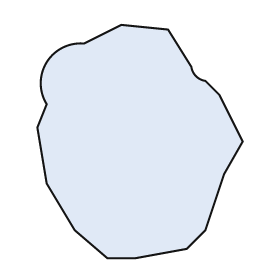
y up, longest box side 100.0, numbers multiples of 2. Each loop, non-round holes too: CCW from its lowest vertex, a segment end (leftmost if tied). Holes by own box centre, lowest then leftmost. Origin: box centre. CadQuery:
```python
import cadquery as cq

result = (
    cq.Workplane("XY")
    .moveTo(-14.0, -50.0)
    .lineTo(-2.0, -50.0)
    .lineTo(20.0, -46.0)
    .lineTo(28.0, -38.0)
    .lineTo(36.0, -14.0)
    .lineTo(44.0, 0.0)
    .lineTo(34.0, 20.0)
    .lineTo(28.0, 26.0)
    .threePointArc((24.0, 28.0), (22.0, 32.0))
    .lineTo(12.0, 48.0)
    .lineTo(-8.0, 50.0)
    .lineTo(-24.0, 42.0)
    .threePointArc((-40.0, 34.0), (-40.0, 16.0))
    .lineTo(-44.0, 6.0)
    .lineTo(-40.0, -18.0)
    .lineTo(-28.0, -38.0)
    .close()
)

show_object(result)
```